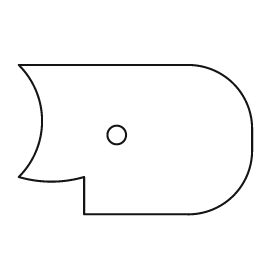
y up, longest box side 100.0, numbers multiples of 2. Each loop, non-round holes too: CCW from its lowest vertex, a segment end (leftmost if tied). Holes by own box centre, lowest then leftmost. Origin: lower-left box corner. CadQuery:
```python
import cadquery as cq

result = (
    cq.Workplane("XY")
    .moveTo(28.0, 0.0)
    .lineTo(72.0, 0.0)
    .threePointArc((92.0, 8.0), (100.0, 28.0))
    .lineTo(100.0, 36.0)
    .threePointArc((92.0, 56.0), (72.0, 64.0))
    .lineTo(0.0, 64.0)
    .threePointArc((10.0, 40.0), (0.0, 16.0))
    .threePointArc((14.0, 14.0), (28.0, 16.0))
    .close()
    .moveTo(42.0, 34.0)
    .circle(4.0)
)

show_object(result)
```